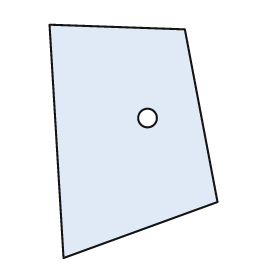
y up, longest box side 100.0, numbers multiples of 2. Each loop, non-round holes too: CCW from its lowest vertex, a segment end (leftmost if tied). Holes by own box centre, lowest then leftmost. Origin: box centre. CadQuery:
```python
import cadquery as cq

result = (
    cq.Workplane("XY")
    .moveTo(-30.0, -50.0)
    .lineTo(36.0, -26.0)
    .lineTo(22.0, 48.0)
    .lineTo(-36.0, 50.0)
    .close()
    .moveTo(6.0, 10.0)
    .circle(4.0)
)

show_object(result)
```